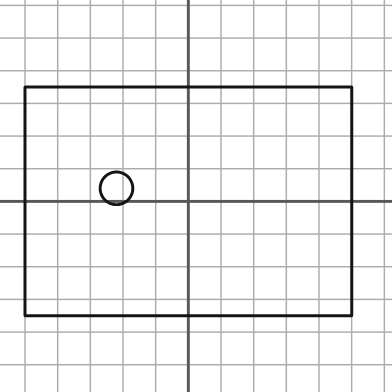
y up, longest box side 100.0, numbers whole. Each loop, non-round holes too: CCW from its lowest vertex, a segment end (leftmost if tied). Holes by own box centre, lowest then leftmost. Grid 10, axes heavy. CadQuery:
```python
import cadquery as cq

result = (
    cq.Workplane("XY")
    .moveTo(-50.0, -35.0)
    .lineTo(50.0, -35.0)
    .lineTo(50.0, 35.0)
    .lineTo(-50.0, 35.0)
    .close()
    .moveTo(-22.0, 4.0)
    .circle(5.0)
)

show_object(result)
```